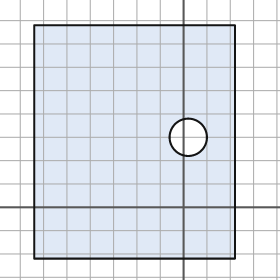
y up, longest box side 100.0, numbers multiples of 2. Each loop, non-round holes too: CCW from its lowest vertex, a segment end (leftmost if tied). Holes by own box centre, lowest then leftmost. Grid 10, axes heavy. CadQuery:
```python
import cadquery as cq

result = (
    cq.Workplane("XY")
    .moveTo(-64.0, -22.0)
    .lineTo(22.0, -22.0)
    .lineTo(22.0, 78.0)
    .lineTo(-64.0, 78.0)
    .close()
    .moveTo(2.0, 30.0)
    .circle(8.0)
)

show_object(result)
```